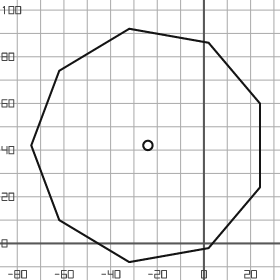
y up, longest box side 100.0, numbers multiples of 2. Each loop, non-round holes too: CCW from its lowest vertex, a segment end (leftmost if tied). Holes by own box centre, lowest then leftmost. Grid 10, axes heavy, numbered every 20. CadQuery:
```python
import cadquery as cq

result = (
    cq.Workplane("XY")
    .moveTo(-32.0, -8.0)
    .lineTo(2.0, -2.0)
    .lineTo(24.0, 24.0)
    .lineTo(24.0, 60.0)
    .lineTo(2.0, 86.0)
    .lineTo(-32.0, 92.0)
    .lineTo(-62.0, 74.0)
    .lineTo(-74.0, 42.0)
    .lineTo(-62.0, 10.0)
    .close()
    .moveTo(-24.0, 42.0)
    .circle(2.0)
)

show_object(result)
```